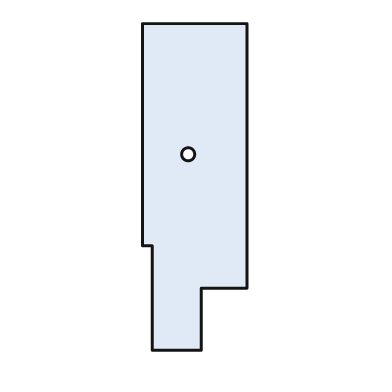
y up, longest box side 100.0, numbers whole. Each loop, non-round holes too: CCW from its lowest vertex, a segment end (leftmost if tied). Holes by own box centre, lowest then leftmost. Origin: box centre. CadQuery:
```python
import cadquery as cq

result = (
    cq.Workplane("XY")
    .moveTo(-13.0, -50.0)
    .lineTo(2.0, -50.0)
    .lineTo(2.0, -31.0)
    .lineTo(16.0, -31.0)
    .lineTo(16.0, 50.0)
    .lineTo(-16.0, 50.0)
    .lineTo(-16.0, -18.0)
    .lineTo(-13.0, -18.0)
    .close()
    .moveTo(-2.0, 10.0)
    .circle(2.0)
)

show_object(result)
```